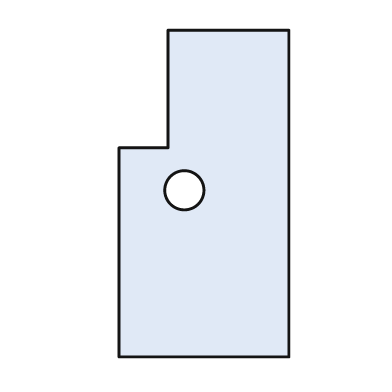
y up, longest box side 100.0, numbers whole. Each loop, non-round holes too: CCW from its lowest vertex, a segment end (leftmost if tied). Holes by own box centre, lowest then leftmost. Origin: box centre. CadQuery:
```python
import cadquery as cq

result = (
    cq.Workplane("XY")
    .moveTo(-26.0, -50.0)
    .lineTo(26.0, -50.0)
    .lineTo(26.0, 50.0)
    .lineTo(-11.0, 50.0)
    .lineTo(-11.0, 14.0)
    .lineTo(-26.0, 14.0)
    .close()
    .moveTo(-6.0, 1.0)
    .circle(6.0)
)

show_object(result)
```